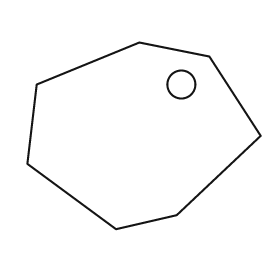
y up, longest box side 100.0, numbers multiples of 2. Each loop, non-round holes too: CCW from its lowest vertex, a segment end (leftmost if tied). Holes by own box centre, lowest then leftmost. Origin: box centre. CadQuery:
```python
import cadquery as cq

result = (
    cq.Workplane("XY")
    .moveTo(-12.0, -40.0)
    .lineTo(14.0, -34.0)
    .lineTo(50.0, 0.0)
    .lineTo(28.0, 34.0)
    .lineTo(-2.0, 40.0)
    .lineTo(-46.0, 22.0)
    .lineTo(-50.0, -12.0)
    .close()
    .moveTo(16.0, 22.0)
    .circle(6.0)
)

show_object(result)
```